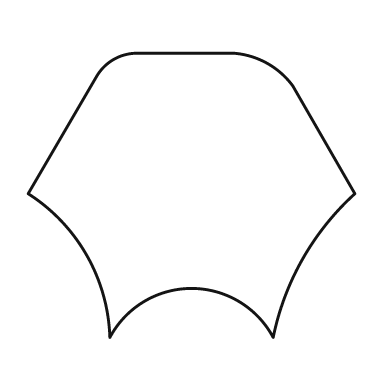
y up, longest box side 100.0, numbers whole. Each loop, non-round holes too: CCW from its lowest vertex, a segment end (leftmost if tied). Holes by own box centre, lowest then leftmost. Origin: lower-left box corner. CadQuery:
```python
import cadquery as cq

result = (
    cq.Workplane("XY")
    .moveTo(25.0, 0.0)
    .threePointArc((50.0, 15.0), (75.0, 0.0))
    .threePointArc((84.0, 24.0), (100.0, 44.0))
    .lineTo(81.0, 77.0)
    .threePointArc((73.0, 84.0), (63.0, 87.0))
    .lineTo(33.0, 87.0)
    .threePointArc((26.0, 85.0), (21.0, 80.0))
    .lineTo(0.0, 44.0)
    .threePointArc((18.0, 25.0), (25.0, 0.0))
    .close()
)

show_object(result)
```